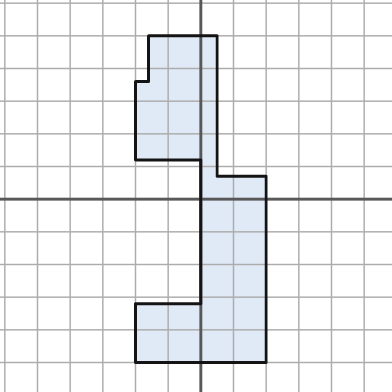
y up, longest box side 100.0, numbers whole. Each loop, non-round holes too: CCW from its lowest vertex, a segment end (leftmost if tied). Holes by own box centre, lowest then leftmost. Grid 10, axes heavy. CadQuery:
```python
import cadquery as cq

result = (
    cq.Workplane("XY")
    .moveTo(-20.0, -50.0)
    .lineTo(20.0, -50.0)
    .lineTo(20.0, 7.0)
    .lineTo(5.0, 7.0)
    .lineTo(5.0, 50.0)
    .lineTo(-16.0, 50.0)
    .lineTo(-16.0, 36.0)
    .lineTo(-20.0, 36.0)
    .lineTo(-20.0, 12.0)
    .lineTo(0.0, 12.0)
    .lineTo(0.0, -32.0)
    .lineTo(-20.0, -32.0)
    .close()
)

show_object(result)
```